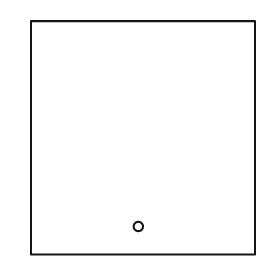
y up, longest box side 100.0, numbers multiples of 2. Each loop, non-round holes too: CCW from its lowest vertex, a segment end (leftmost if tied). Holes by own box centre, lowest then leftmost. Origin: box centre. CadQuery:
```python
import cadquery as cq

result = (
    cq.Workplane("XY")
    .moveTo(-48.0, -50.0)
    .lineTo(48.0, -50.0)
    .lineTo(48.0, 50.0)
    .lineTo(-48.0, 50.0)
    .close()
    .moveTo(-2.0, -38.0)
    .circle(2.0)
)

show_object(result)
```